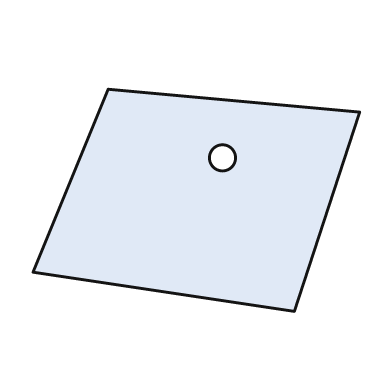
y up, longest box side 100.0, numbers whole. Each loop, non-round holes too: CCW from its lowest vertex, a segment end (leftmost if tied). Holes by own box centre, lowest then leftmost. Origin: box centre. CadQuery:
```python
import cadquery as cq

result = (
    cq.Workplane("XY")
    .moveTo(30.0, -34.0)
    .lineTo(50.0, 27.0)
    .lineTo(-27.0, 34.0)
    .lineTo(-50.0, -22.0)
    .close()
    .moveTo(8.0, 13.0)
    .circle(4.0)
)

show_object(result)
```